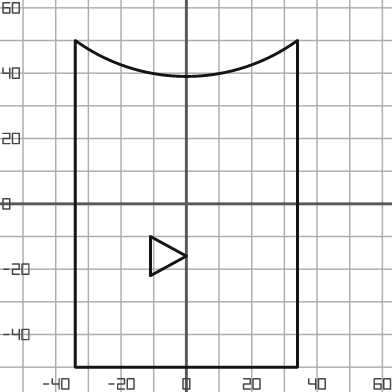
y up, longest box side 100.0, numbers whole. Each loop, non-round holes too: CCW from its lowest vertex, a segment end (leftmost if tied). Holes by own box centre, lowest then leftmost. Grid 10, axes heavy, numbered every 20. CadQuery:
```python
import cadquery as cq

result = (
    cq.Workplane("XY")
    .moveTo(-34.0, -50.0)
    .lineTo(34.0, -50.0)
    .lineTo(34.0, 50.0)
    .threePointArc((0.0, 39.0), (-34.0, 50.0))
    .close()
    .moveTo(-11.0, -22.0)
    .lineTo(0.0, -16.0)
    .lineTo(-11.0, -10.0)
    .close()
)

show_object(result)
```